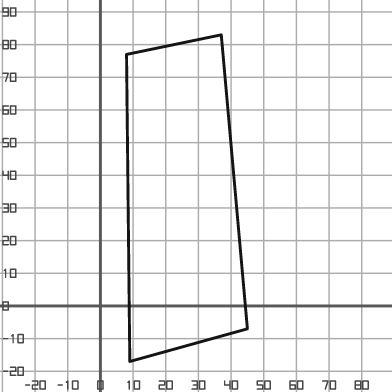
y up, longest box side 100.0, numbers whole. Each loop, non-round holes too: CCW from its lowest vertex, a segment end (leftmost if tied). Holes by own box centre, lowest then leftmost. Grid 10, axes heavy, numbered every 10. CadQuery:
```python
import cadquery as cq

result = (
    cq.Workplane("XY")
    .moveTo(9.0, -17.0)
    .lineTo(45.0, -7.0)
    .lineTo(37.0, 83.0)
    .lineTo(8.0, 77.0)
    .close()
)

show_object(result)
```